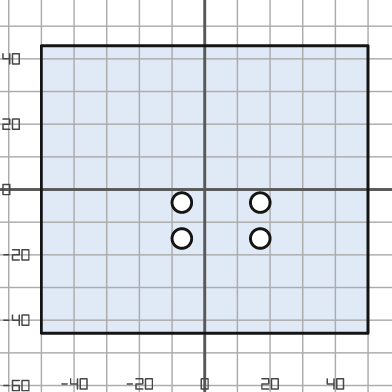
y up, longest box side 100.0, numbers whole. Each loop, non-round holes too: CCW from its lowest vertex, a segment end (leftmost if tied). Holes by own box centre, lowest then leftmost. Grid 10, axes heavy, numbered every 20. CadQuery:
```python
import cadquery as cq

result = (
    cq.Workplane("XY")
    .moveTo(-50.0, -44.0)
    .lineTo(50.0, -44.0)
    .lineTo(50.0, 44.0)
    .lineTo(-50.0, 44.0)
    .close()
    .moveTo(-7.0, -15.0)
    .circle(3.0)
    .moveTo(17.0, -15.0)
    .circle(3.0)
    .moveTo(-7.0, -4.0)
    .circle(3.0)
    .moveTo(17.0, -4.0)
    .circle(3.0)
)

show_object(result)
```